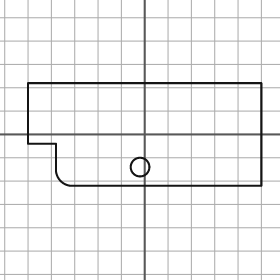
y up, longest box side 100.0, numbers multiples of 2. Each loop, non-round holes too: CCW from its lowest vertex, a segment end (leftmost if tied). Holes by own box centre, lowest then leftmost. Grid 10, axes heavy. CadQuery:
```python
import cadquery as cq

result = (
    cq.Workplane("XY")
    .moveTo(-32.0, -22.0)
    .lineTo(50.0, -22.0)
    .lineTo(50.0, 22.0)
    .lineTo(-50.0, 22.0)
    .lineTo(-50.0, -4.0)
    .lineTo(-38.0, -4.0)
    .lineTo(-38.0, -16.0)
    .threePointArc((-36.0, -20.0), (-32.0, -22.0))
    .close()
    .moveTo(-2.0, -14.0)
    .circle(4.0)
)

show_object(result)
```